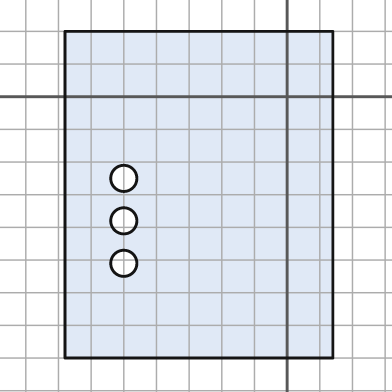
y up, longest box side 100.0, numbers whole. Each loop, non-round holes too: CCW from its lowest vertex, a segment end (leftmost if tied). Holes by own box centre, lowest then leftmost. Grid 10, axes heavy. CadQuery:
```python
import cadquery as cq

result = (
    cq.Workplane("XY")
    .moveTo(-68.0, -80.0)
    .lineTo(14.0, -80.0)
    .lineTo(14.0, 20.0)
    .lineTo(-68.0, 20.0)
    .close()
    .moveTo(-50.0, -51.0)
    .circle(4.0)
    .moveTo(-50.0, -38.0)
    .circle(4.0)
    .moveTo(-50.0, -25.0)
    .circle(4.0)
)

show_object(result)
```